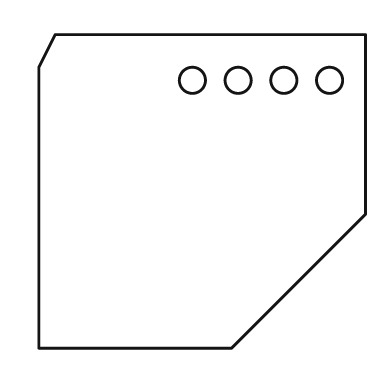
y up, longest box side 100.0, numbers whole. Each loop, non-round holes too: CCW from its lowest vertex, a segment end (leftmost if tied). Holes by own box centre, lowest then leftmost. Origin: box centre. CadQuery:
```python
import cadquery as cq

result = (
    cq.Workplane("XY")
    .moveTo(-50.0, -48.0)
    .lineTo(9.0, -48.0)
    .lineTo(50.0, -7.0)
    .lineTo(50.0, 48.0)
    .lineTo(-45.0, 48.0)
    .lineTo(-50.0, 38.0)
    .close()
    .moveTo(-3.0, 34.0)
    .circle(4.0)
    .moveTo(11.0, 34.0)
    .circle(4.0)
    .moveTo(25.0, 34.0)
    .circle(4.0)
    .moveTo(39.0, 34.0)
    .circle(4.0)
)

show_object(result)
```